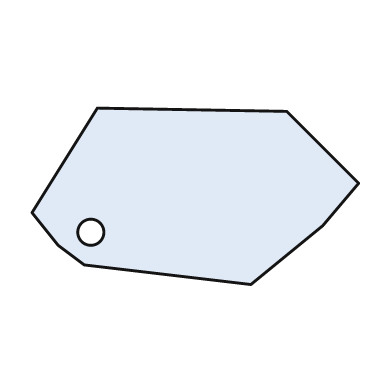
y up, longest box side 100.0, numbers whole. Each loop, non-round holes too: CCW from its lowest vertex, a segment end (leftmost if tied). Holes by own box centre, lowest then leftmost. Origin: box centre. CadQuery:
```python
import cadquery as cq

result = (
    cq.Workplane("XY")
    .moveTo(17.0, -27.0)
    .lineTo(39.0, -9.0)
    .lineTo(50.0, 4.0)
    .lineTo(28.0, 26.0)
    .lineTo(-30.0, 27.0)
    .lineTo(-50.0, -5.0)
    .lineTo(-42.0, -15.0)
    .lineTo(-34.0, -21.0)
    .close()
    .moveTo(-32.0, -11.0)
    .circle(4.0)
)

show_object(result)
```